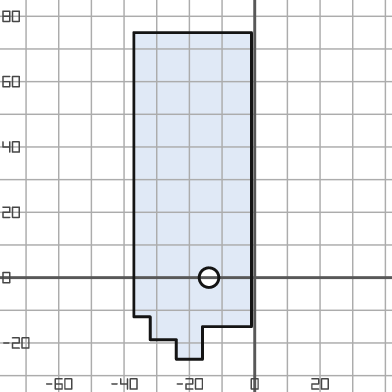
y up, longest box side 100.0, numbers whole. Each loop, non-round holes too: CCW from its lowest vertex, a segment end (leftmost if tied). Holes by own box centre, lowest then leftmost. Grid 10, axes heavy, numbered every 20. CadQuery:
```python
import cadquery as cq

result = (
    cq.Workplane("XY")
    .moveTo(-24.0, -25.0)
    .lineTo(-16.0, -25.0)
    .lineTo(-16.0, -15.0)
    .lineTo(-1.0, -15.0)
    .lineTo(-1.0, 75.0)
    .lineTo(-37.0, 75.0)
    .lineTo(-37.0, -12.0)
    .lineTo(-32.0, -12.0)
    .lineTo(-32.0, -19.0)
    .lineTo(-24.0, -19.0)
    .close()
    .moveTo(-14.0, 0.0)
    .circle(3.0)
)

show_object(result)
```